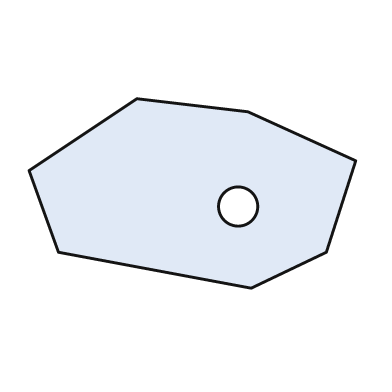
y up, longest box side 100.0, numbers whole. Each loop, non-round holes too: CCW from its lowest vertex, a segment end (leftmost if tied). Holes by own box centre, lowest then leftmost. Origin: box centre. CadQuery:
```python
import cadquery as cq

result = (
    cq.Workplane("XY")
    .moveTo(18.0, -29.0)
    .lineTo(41.0, -18.0)
    .lineTo(50.0, 10.0)
    .lineTo(17.0, 25.0)
    .lineTo(-17.0, 29.0)
    .lineTo(-50.0, 7.0)
    .lineTo(-41.0, -18.0)
    .close()
    .moveTo(14.0, -4.0)
    .circle(6.0)
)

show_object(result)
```